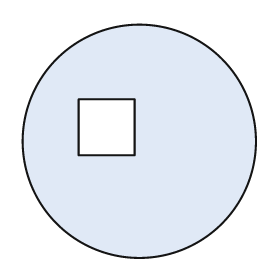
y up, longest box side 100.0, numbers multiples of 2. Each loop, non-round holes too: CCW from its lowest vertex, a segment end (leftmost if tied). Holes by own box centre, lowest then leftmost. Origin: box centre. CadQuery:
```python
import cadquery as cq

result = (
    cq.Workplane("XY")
    .moveTo(0.0, 0.0)
    .circle(50.0)
    .moveTo(-26.0, -6.0)
    .lineTo(-2.0, -6.0)
    .lineTo(-2.0, 18.0)
    .lineTo(-26.0, 18.0)
    .close()
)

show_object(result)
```